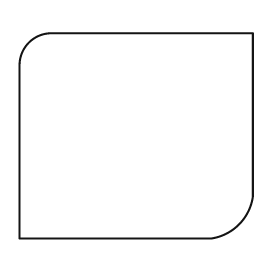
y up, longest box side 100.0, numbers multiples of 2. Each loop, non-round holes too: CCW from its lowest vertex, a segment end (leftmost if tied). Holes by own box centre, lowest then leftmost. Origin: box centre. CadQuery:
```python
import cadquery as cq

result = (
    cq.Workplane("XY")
    .moveTo(-50.0, -44.0)
    .lineTo(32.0, -44.0)
    .threePointArc((44.0, -38.0), (50.0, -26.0))
    .lineTo(50.0, 44.0)
    .lineTo(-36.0, 44.0)
    .threePointArc((-46.0, 40.0), (-50.0, 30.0))
    .close()
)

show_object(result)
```